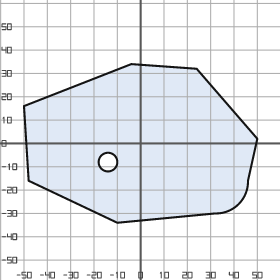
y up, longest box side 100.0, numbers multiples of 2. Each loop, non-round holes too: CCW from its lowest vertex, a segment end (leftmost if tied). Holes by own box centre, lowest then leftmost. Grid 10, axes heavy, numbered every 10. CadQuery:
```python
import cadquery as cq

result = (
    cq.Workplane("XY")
    .moveTo(-10.0, -34.0)
    .lineTo(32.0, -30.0)
    .threePointArc((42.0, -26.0), (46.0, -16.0))
    .lineTo(50.0, 2.0)
    .lineTo(24.0, 32.0)
    .lineTo(-4.0, 34.0)
    .lineTo(-50.0, 16.0)
    .lineTo(-48.0, -16.0)
    .close()
    .moveTo(-14.0, -8.0)
    .circle(4.0)
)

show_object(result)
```